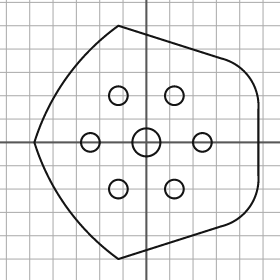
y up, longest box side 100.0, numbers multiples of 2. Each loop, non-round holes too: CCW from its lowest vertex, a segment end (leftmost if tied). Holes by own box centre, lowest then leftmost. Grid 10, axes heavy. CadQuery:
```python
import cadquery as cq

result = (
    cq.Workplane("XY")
    .moveTo(-12.0, -50.0)
    .lineTo(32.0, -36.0)
    .threePointArc((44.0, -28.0), (48.0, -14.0))
    .lineTo(48.0, 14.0)
    .threePointArc((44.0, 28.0), (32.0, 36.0))
    .lineTo(-12.0, 50.0)
    .threePointArc((-34.0, 28.0), (-48.0, 0.0))
    .threePointArc((-34.0, -28.0), (-12.0, -50.0))
    .close()
    .moveTo(-12.0, -20.0)
    .circle(4.0)
    .moveTo(12.0, -20.0)
    .circle(4.0)
    .moveTo(-24.0, 0.0)
    .circle(4.0)
    .moveTo(0.0, 0.0)
    .circle(6.0)
    .moveTo(24.0, 0.0)
    .circle(4.0)
    .moveTo(-12.0, 20.0)
    .circle(4.0)
    .moveTo(12.0, 20.0)
    .circle(4.0)
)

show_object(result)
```